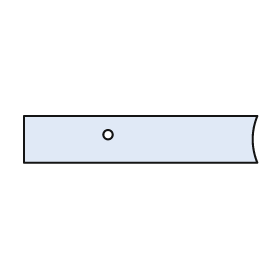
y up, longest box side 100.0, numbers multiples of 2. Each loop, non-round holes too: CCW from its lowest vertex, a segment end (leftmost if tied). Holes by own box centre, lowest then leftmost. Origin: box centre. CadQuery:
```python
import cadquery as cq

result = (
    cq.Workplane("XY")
    .moveTo(-50.0, -10.0)
    .lineTo(50.0, -10.0)
    .threePointArc((48.0, 0.0), (50.0, 10.0))
    .lineTo(-50.0, 10.0)
    .close()
    .moveTo(-14.0, 2.0)
    .circle(2.0)
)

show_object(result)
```